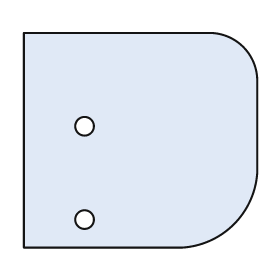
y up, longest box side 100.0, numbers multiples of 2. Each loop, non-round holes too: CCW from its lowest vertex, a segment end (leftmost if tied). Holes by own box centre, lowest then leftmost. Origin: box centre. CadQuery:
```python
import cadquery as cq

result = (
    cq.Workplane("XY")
    .moveTo(-50.0, -46.0)
    .lineTo(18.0, -46.0)
    .threePointArc((40.0, -36.0), (50.0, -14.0))
    .lineTo(50.0, 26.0)
    .threePointArc((44.0, 40.0), (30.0, 46.0))
    .lineTo(-50.0, 46.0)
    .close()
    .moveTo(-24.0, -34.0)
    .circle(4.0)
    .moveTo(-24.0, 6.0)
    .circle(4.0)
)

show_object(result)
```